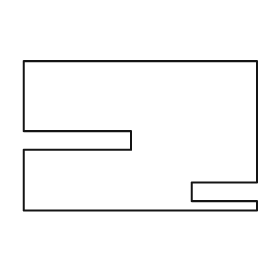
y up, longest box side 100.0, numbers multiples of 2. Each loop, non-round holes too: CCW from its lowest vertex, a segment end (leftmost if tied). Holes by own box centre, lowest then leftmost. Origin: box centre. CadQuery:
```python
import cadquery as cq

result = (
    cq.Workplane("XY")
    .moveTo(-50.0, -32.0)
    .lineTo(50.0, -32.0)
    .lineTo(50.0, -28.0)
    .lineTo(22.0, -28.0)
    .lineTo(22.0, -20.0)
    .lineTo(50.0, -20.0)
    .lineTo(50.0, 32.0)
    .lineTo(-50.0, 32.0)
    .lineTo(-50.0, 2.0)
    .lineTo(-4.0, 2.0)
    .lineTo(-4.0, -6.0)
    .lineTo(-50.0, -6.0)
    .close()
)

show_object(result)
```